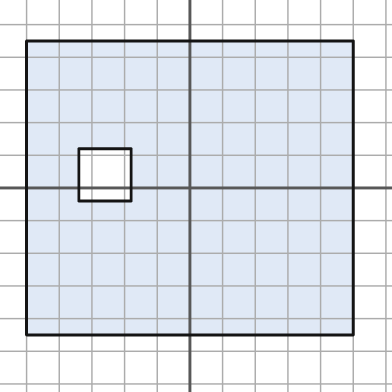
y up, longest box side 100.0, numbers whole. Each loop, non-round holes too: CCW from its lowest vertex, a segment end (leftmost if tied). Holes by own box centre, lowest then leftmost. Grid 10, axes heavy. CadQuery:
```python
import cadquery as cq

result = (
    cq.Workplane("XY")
    .moveTo(-50.0, -45.0)
    .lineTo(50.0, -45.0)
    .lineTo(50.0, 45.0)
    .lineTo(-50.0, 45.0)
    .close()
    .moveTo(-34.0, -4.0)
    .lineTo(-18.0, -4.0)
    .lineTo(-18.0, 12.0)
    .lineTo(-34.0, 12.0)
    .close()
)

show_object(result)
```